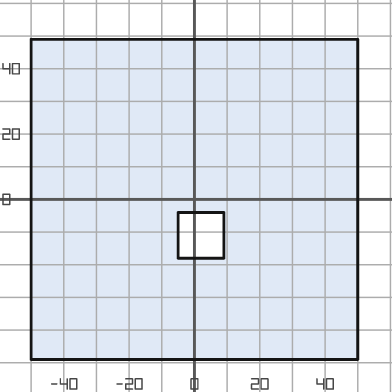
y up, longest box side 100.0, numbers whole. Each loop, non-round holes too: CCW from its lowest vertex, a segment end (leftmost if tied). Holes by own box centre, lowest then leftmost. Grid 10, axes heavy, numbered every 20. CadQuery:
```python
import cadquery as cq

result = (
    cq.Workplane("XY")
    .moveTo(-50.0, -49.0)
    .lineTo(50.0, -49.0)
    .lineTo(50.0, 49.0)
    .lineTo(-50.0, 49.0)
    .close()
    .moveTo(-5.0, -18.0)
    .lineTo(9.0, -18.0)
    .lineTo(9.0, -4.0)
    .lineTo(-5.0, -4.0)
    .close()
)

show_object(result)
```